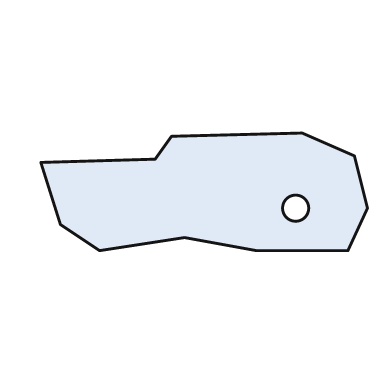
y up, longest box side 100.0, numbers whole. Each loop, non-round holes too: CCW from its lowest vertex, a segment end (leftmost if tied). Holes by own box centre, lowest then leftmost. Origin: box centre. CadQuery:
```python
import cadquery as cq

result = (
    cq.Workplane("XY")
    .moveTo(-32.0, -18.0)
    .lineTo(-6.0, -14.0)
    .lineTo(16.0, -18.0)
    .lineTo(44.0, -18.0)
    .lineTo(50.0, -5.0)
    .lineTo(46.0, 11.0)
    .lineTo(30.0, 18.0)
    .lineTo(-10.0, 17.0)
    .lineTo(-15.0, 10.0)
    .lineTo(-50.0, 9.0)
    .lineTo(-44.0, -10.0)
    .close()
    .moveTo(28.0, -5.0)
    .circle(4.0)
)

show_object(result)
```